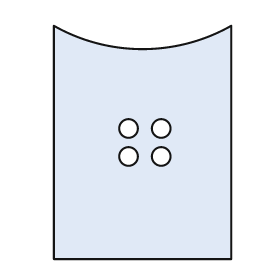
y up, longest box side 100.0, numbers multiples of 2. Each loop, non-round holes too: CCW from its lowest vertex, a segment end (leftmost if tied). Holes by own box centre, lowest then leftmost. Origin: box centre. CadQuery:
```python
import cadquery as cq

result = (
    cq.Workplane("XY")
    .moveTo(-38.0, -50.0)
    .lineTo(38.0, -50.0)
    .lineTo(38.0, 50.0)
    .threePointArc((0.0, 40.0), (-38.0, 50.0))
    .close()
    .moveTo(-6.0, -6.0)
    .circle(4.0)
    .moveTo(8.0, -6.0)
    .circle(4.0)
    .moveTo(-6.0, 6.0)
    .circle(4.0)
    .moveTo(8.0, 6.0)
    .circle(4.0)
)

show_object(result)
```